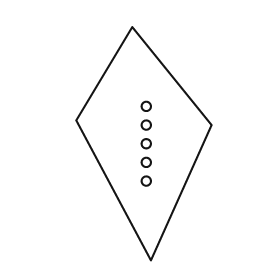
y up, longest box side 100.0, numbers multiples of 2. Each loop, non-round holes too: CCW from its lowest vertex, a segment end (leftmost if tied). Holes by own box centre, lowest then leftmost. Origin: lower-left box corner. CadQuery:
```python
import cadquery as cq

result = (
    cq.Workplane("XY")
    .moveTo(32.0, 0.0)
    .lineTo(58.0, 58.0)
    .lineTo(24.0, 100.0)
    .lineTo(0.0, 60.0)
    .close()
    .moveTo(30.0, 34.0)
    .circle(2.0)
    .moveTo(30.0, 42.0)
    .circle(2.0)
    .moveTo(30.0, 50.0)
    .circle(2.0)
    .moveTo(30.0, 58.0)
    .circle(2.0)
    .moveTo(30.0, 66.0)
    .circle(2.0)
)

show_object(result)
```